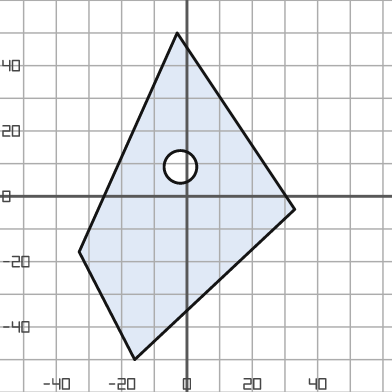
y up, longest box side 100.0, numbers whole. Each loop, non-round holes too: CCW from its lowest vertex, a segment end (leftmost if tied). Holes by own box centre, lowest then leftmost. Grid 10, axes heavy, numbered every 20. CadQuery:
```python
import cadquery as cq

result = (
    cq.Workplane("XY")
    .moveTo(-16.0, -50.0)
    .lineTo(33.0, -4.0)
    .lineTo(-3.0, 50.0)
    .lineTo(-33.0, -17.0)
    .close()
    .moveTo(-2.0, 9.0)
    .circle(5.0)
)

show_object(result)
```